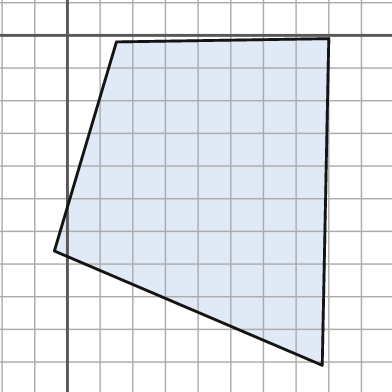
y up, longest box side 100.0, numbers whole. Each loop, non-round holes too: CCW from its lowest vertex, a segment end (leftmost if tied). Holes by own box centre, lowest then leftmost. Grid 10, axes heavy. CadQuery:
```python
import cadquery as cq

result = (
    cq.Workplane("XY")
    .moveTo(78.0, -101.0)
    .lineTo(80.0, -1.0)
    .lineTo(15.0, -2.0)
    .lineTo(-4.0, -66.0)
    .close()
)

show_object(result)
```